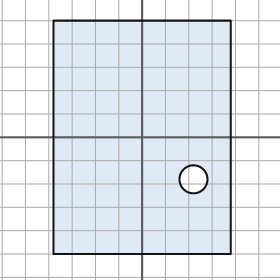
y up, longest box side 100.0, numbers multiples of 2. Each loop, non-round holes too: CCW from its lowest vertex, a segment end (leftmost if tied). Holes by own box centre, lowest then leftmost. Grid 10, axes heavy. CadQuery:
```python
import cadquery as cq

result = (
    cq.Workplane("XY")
    .moveTo(-38.0, -50.0)
    .lineTo(38.0, -50.0)
    .lineTo(38.0, 50.0)
    .lineTo(-38.0, 50.0)
    .close()
    .moveTo(22.0, -18.0)
    .circle(6.0)
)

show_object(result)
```